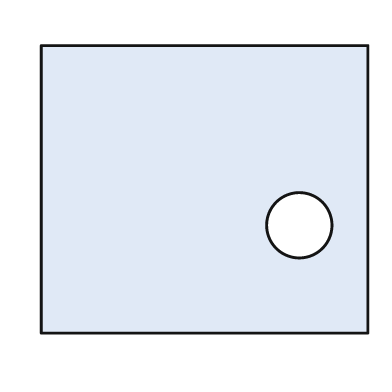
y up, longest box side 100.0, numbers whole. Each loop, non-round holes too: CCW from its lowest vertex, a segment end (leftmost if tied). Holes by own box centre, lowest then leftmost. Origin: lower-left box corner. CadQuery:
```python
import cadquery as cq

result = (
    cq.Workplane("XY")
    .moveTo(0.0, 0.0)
    .lineTo(100.0, 0.0)
    .lineTo(100.0, 88.0)
    .lineTo(0.0, 88.0)
    .close()
    .moveTo(79.0, 33.0)
    .circle(10.0)
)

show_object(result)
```